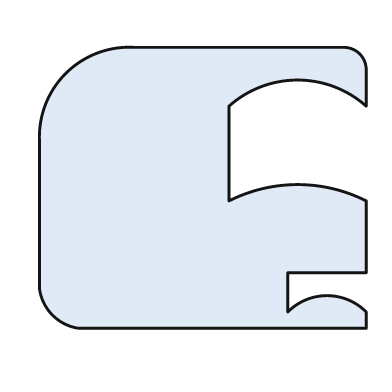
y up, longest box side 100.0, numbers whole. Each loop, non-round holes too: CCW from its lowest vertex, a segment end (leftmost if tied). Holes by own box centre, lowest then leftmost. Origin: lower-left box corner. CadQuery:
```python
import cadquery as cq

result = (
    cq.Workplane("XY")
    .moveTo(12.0, 0.0)
    .lineTo(100.0, 0.0)
    .lineTo(100.0, 5.0)
    .threePointArc((88.0, 10.0), (76.0, 5.0))
    .lineTo(76.0, 17.0)
    .lineTo(100.0, 17.0)
    .lineTo(100.0, 39.0)
    .threePointArc((79.0, 44.0), (58.0, 39.0))
    .lineTo(58.0, 68.0)
    .threePointArc((79.0, 76.0), (100.0, 68.0))
    .lineTo(100.0, 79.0)
    .threePointArc((98.0, 84.0), (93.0, 86.0))
    .lineTo(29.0, 86.0)
    .threePointArc((8.0, 78.0), (0.0, 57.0))
    .lineTo(0.0, 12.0)
    .threePointArc((4.0, 4.0), (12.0, 0.0))
    .close()
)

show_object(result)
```